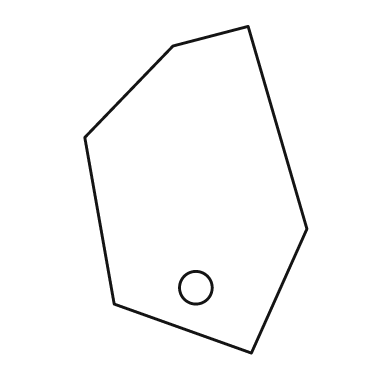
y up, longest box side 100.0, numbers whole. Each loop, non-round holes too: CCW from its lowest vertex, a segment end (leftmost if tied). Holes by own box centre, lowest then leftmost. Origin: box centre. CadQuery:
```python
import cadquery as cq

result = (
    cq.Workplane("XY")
    .moveTo(17.0, -50.0)
    .lineTo(34.0, -12.0)
    .lineTo(16.0, 50.0)
    .lineTo(-7.0, 44.0)
    .lineTo(-34.0, 16.0)
    .lineTo(-25.0, -35.0)
    .close()
    .moveTo(0.0, -30.0)
    .circle(5.0)
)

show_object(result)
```